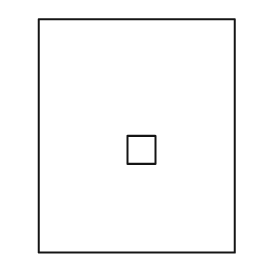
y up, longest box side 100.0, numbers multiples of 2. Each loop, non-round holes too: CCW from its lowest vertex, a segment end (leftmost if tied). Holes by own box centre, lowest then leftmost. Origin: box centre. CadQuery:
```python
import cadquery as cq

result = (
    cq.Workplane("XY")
    .moveTo(-42.0, -50.0)
    .lineTo(42.0, -50.0)
    .lineTo(42.0, 50.0)
    .lineTo(-42.0, 50.0)
    .close()
    .moveTo(-4.0, -12.0)
    .lineTo(8.0, -12.0)
    .lineTo(8.0, 0.0)
    .lineTo(-4.0, 0.0)
    .close()
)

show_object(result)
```